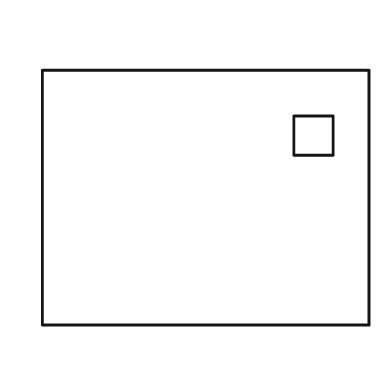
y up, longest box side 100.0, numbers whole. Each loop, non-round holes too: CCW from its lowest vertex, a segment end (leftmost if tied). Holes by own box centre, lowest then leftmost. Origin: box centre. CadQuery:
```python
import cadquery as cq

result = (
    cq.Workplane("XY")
    .moveTo(-50.0, -39.0)
    .lineTo(50.0, -39.0)
    .lineTo(50.0, 39.0)
    .lineTo(-50.0, 39.0)
    .close()
    .moveTo(27.0, 13.0)
    .lineTo(39.0, 13.0)
    .lineTo(39.0, 25.0)
    .lineTo(27.0, 25.0)
    .close()
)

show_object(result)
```